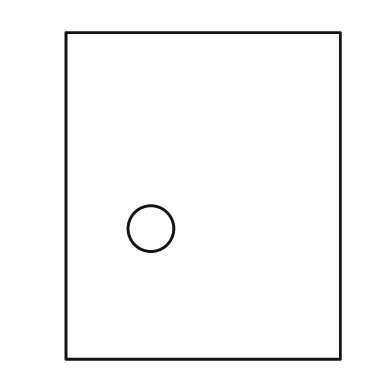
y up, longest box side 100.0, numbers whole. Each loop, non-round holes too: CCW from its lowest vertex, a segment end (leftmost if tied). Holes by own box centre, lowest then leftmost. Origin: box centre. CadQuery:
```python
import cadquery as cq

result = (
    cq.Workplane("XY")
    .moveTo(-42.0, -50.0)
    .lineTo(42.0, -50.0)
    .lineTo(42.0, 50.0)
    .lineTo(-42.0, 50.0)
    .close()
    .moveTo(-16.0, -10.0)
    .circle(7.0)
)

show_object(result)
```